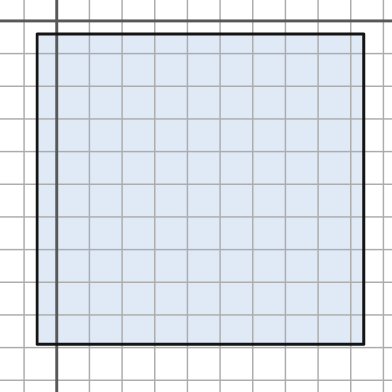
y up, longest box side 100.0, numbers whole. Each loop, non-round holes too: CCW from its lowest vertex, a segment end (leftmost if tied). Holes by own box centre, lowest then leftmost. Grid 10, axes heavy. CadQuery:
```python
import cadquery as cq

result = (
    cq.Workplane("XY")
    .moveTo(-6.0, -99.0)
    .lineTo(94.0, -99.0)
    .lineTo(94.0, -4.0)
    .lineTo(-6.0, -4.0)
    .close()
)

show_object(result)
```